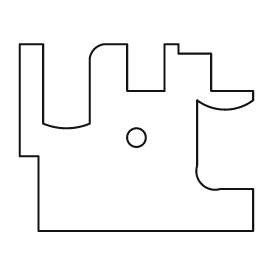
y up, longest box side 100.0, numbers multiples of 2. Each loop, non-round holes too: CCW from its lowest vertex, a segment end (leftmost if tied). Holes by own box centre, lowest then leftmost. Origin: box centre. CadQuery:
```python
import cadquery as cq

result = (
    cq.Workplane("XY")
    .moveTo(-42.0, -40.0)
    .lineTo(50.0, -40.0)
    .lineTo(50.0, -22.0)
    .lineTo(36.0, -22.0)
    .threePointArc((28.0, -20.0), (26.0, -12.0))
    .lineTo(26.0, 16.0)
    .threePointArc((38.0, 12.0), (50.0, 16.0))
    .lineTo(50.0, 20.0)
    .lineTo(32.0, 20.0)
    .lineTo(32.0, 36.0)
    .lineTo(18.0, 36.0)
    .lineTo(18.0, 40.0)
    .lineTo(12.0, 40.0)
    .lineTo(12.0, 20.0)
    .lineTo(-4.0, 20.0)
    .lineTo(-4.0, 40.0)
    .lineTo(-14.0, 40.0)
    .threePointArc((-18.0, 38.0), (-20.0, 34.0))
    .lineTo(-20.0, 6.0)
    .threePointArc((-30.0, 4.0), (-40.0, 6.0))
    .lineTo(-40.0, 40.0)
    .lineTo(-50.0, 40.0)
    .lineTo(-50.0, -8.0)
    .lineTo(-42.0, -8.0)
    .close()
    .moveTo(0.0, 0.0)
    .circle(4.0)
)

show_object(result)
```